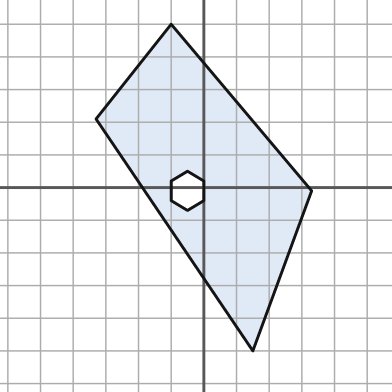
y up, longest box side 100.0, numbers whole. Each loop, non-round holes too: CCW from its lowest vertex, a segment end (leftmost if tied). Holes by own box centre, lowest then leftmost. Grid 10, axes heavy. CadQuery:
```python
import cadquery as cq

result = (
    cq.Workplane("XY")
    .moveTo(15.0, -50.0)
    .lineTo(33.0, -1.0)
    .lineTo(-10.0, 50.0)
    .lineTo(-33.0, 21.0)
    .close()
    .moveTo(-5.0, -7.0)
    .lineTo(0.0, -4.0)
    .lineTo(0.0, 2.0)
    .lineTo(-5.0, 5.0)
    .lineTo(-10.0, 2.0)
    .lineTo(-10.0, -4.0)
    .close()
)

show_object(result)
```